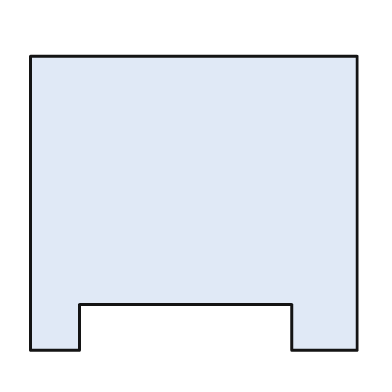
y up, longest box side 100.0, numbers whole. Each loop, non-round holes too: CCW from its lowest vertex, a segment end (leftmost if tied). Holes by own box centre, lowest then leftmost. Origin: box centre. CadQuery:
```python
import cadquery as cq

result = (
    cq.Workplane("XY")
    .moveTo(-50.0, -45.0)
    .lineTo(-35.0, -45.0)
    .lineTo(-35.0, -31.0)
    .lineTo(30.0, -31.0)
    .lineTo(30.0, -45.0)
    .lineTo(50.0, -45.0)
    .lineTo(50.0, 45.0)
    .lineTo(-50.0, 45.0)
    .close()
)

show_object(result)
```